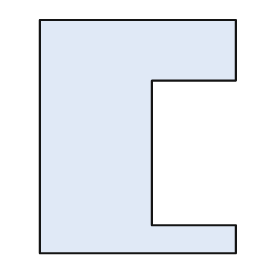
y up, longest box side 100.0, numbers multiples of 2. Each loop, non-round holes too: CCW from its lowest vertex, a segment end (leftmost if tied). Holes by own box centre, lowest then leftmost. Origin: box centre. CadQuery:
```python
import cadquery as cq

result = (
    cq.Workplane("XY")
    .moveTo(-42.0, -50.0)
    .lineTo(42.0, -50.0)
    .lineTo(42.0, -38.0)
    .lineTo(6.0, -38.0)
    .lineTo(6.0, 24.0)
    .lineTo(42.0, 24.0)
    .lineTo(42.0, 50.0)
    .lineTo(-42.0, 50.0)
    .close()
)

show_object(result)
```